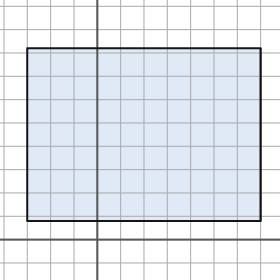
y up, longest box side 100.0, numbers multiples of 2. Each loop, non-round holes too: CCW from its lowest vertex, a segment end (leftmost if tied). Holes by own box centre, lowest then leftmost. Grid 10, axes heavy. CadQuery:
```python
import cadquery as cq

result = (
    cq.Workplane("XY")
    .moveTo(-30.0, 8.0)
    .lineTo(70.0, 8.0)
    .lineTo(70.0, 82.0)
    .lineTo(-30.0, 82.0)
    .close()
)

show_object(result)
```